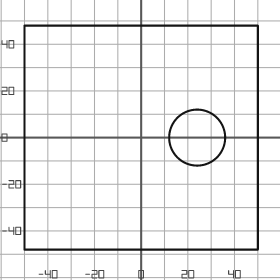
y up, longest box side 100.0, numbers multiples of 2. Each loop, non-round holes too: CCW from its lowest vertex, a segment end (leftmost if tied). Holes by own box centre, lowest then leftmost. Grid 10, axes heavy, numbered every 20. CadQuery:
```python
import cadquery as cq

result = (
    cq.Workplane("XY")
    .moveTo(-50.0, -48.0)
    .lineTo(50.0, -48.0)
    .lineTo(50.0, 48.0)
    .lineTo(-50.0, 48.0)
    .close()
    .moveTo(24.0, 0.0)
    .circle(12.0)
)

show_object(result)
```